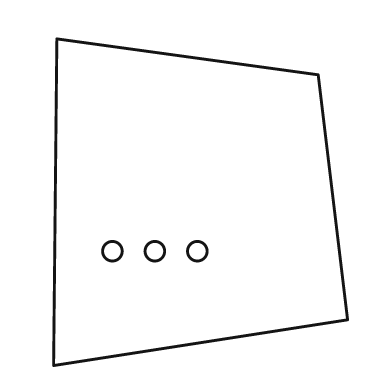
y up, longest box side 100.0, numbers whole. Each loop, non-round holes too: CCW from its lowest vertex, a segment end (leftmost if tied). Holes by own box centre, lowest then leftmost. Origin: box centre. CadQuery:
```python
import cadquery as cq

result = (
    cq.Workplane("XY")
    .moveTo(-45.0, -50.0)
    .lineTo(45.0, -36.0)
    .lineTo(36.0, 39.0)
    .lineTo(-44.0, 50.0)
    .close()
    .moveTo(-27.0, -15.0)
    .circle(3.0)
    .moveTo(-14.0, -15.0)
    .circle(3.0)
    .moveTo(-1.0, -15.0)
    .circle(3.0)
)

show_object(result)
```